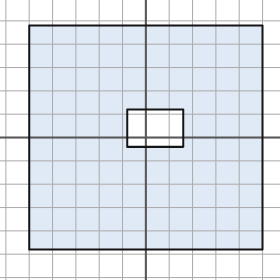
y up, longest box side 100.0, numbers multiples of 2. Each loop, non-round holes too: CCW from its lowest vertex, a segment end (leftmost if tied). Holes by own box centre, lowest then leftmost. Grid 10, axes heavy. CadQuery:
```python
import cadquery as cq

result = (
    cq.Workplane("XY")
    .moveTo(-50.0, -48.0)
    .lineTo(50.0, -48.0)
    .lineTo(50.0, 48.0)
    .lineTo(-50.0, 48.0)
    .close()
    .moveTo(-8.0, -4.0)
    .lineTo(16.0, -4.0)
    .lineTo(16.0, 12.0)
    .lineTo(-8.0, 12.0)
    .close()
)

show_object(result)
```